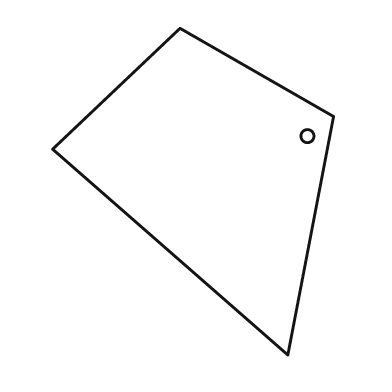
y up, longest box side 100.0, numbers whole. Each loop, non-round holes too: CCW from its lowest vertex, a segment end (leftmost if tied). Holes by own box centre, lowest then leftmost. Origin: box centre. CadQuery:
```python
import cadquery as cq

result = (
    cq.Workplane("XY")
    .moveTo(29.0, -50.0)
    .lineTo(43.0, 23.0)
    .lineTo(-4.0, 50.0)
    .lineTo(-43.0, 13.0)
    .close()
    .moveTo(35.0, 17.0)
    .circle(2.0)
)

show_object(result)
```